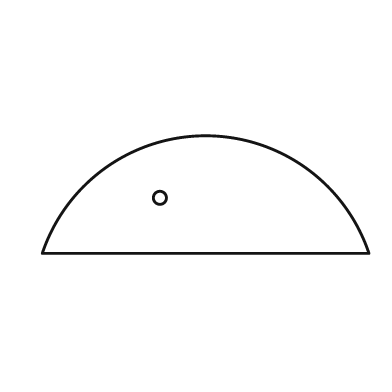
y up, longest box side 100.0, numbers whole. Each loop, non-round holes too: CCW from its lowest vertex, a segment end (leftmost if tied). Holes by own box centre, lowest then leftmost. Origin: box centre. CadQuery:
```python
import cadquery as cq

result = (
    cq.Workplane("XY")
    .moveTo(-50.0, -18.0)
    .lineTo(50.0, -18.0)
    .threePointArc((0.0, 18.0), (-50.0, -18.0))
    .close()
    .moveTo(-14.0, -1.0)
    .circle(2.0)
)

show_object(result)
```